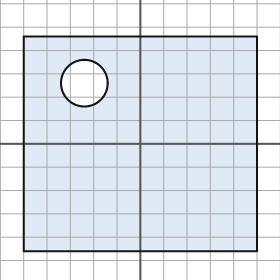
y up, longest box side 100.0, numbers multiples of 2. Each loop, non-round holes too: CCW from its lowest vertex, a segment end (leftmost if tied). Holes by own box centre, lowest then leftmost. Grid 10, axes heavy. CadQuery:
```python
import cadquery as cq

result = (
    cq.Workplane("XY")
    .moveTo(-50.0, -46.0)
    .lineTo(50.0, -46.0)
    .lineTo(50.0, 46.0)
    .lineTo(-50.0, 46.0)
    .close()
    .moveTo(-24.0, 26.0)
    .circle(10.0)
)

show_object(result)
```